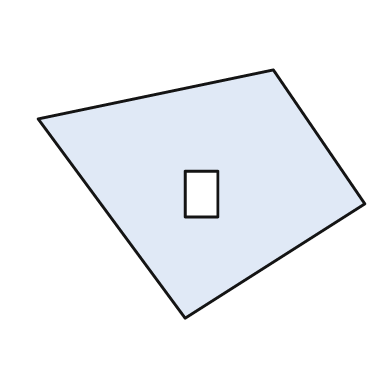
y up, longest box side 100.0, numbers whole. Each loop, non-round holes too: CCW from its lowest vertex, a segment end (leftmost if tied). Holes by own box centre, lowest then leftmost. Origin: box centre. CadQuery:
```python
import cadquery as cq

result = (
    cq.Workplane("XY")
    .moveTo(-5.0, -38.0)
    .lineTo(50.0, -3.0)
    .lineTo(22.0, 38.0)
    .lineTo(-50.0, 23.0)
    .close()
    .moveTo(-5.0, -7.0)
    .lineTo(5.0, -7.0)
    .lineTo(5.0, 7.0)
    .lineTo(-5.0, 7.0)
    .close()
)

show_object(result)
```